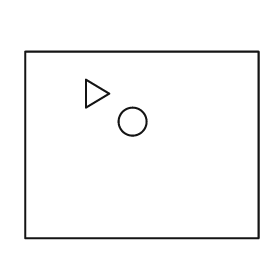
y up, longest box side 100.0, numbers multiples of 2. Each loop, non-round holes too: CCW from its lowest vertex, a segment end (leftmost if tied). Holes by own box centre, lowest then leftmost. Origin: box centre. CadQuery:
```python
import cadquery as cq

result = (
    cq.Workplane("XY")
    .moveTo(-50.0, -40.0)
    .lineTo(50.0, -40.0)
    .lineTo(50.0, 40.0)
    .lineTo(-50.0, 40.0)
    .close()
    .moveTo(-4.0, 10.0)
    .circle(6.0)
    .moveTo(-24.0, 16.0)
    .lineTo(-14.0, 22.0)
    .lineTo(-24.0, 28.0)
    .close()
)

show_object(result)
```